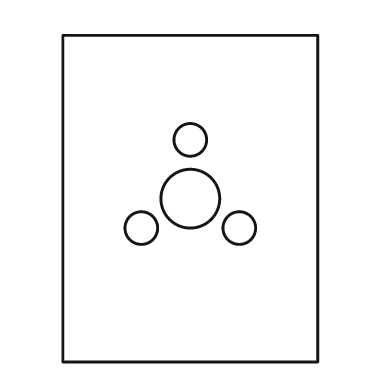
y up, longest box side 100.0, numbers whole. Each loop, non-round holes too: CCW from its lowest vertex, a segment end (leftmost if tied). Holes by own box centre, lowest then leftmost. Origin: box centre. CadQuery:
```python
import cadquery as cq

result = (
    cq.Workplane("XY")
    .moveTo(-39.0, -50.0)
    .lineTo(39.0, -50.0)
    .lineTo(39.0, 50.0)
    .lineTo(-39.0, 50.0)
    .close()
    .moveTo(-15.0, -9.0)
    .circle(5.0)
    .moveTo(15.0, -9.0)
    .circle(5.0)
    .moveTo(0.0, 0.0)
    .circle(9.0)
    .moveTo(0.0, 18.0)
    .circle(5.0)
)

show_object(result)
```